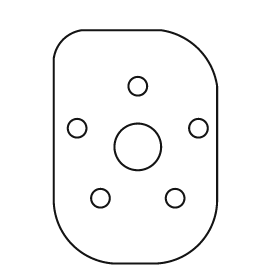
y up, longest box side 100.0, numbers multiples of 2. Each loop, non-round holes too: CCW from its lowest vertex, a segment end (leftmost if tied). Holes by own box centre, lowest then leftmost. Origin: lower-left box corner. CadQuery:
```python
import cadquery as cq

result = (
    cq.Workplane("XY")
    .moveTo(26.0, 0.0)
    .lineTo(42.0, 0.0)
    .threePointArc((62.0, 8.0), (70.0, 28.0))
    .lineTo(70.0, 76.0)
    .threePointArc((62.0, 92.0), (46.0, 100.0))
    .lineTo(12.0, 100.0)
    .threePointArc((4.0, 96.0), (0.0, 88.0))
    .lineTo(0.0, 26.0)
    .threePointArc((8.0, 8.0), (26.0, 0.0))
    .close()
    .moveTo(20.0, 28.0)
    .circle(4.0)
    .moveTo(52.0, 28.0)
    .circle(4.0)
    .moveTo(36.0, 50.0)
    .circle(10.0)
    .moveTo(10.0, 58.0)
    .circle(4.0)
    .moveTo(62.0, 58.0)
    .circle(4.0)
    .moveTo(36.0, 76.0)
    .circle(4.0)
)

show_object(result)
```